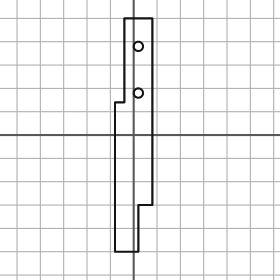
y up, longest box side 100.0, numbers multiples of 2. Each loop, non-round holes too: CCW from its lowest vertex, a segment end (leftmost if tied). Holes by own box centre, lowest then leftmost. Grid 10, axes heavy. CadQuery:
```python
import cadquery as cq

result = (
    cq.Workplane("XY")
    .moveTo(-8.0, -50.0)
    .lineTo(2.0, -50.0)
    .lineTo(2.0, -30.0)
    .lineTo(8.0, -30.0)
    .lineTo(8.0, 50.0)
    .lineTo(-4.0, 50.0)
    .lineTo(-4.0, 14.0)
    .lineTo(-8.0, 14.0)
    .close()
    .moveTo(2.0, 18.0)
    .circle(2.0)
    .moveTo(2.0, 38.0)
    .circle(2.0)
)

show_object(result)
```